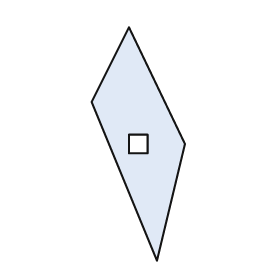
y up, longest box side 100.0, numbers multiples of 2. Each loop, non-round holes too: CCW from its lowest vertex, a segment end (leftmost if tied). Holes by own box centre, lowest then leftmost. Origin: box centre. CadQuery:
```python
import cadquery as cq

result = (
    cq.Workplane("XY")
    .moveTo(8.0, -50.0)
    .lineTo(20.0, 0.0)
    .lineTo(-4.0, 50.0)
    .lineTo(-20.0, 18.0)
    .close()
    .moveTo(-4.0, -4.0)
    .lineTo(4.0, -4.0)
    .lineTo(4.0, 4.0)
    .lineTo(-4.0, 4.0)
    .close()
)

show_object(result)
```